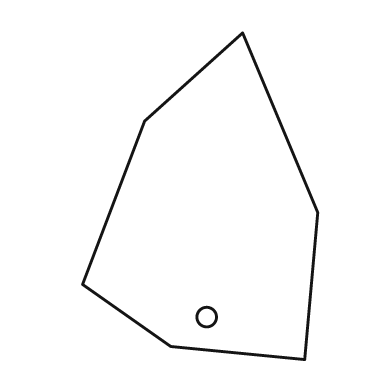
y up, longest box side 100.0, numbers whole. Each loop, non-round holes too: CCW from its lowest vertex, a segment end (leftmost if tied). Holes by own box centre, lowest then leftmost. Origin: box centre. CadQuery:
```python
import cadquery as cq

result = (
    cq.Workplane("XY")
    .moveTo(32.0, -50.0)
    .lineTo(36.0, -5.0)
    .lineTo(13.0, 50.0)
    .lineTo(-17.0, 23.0)
    .lineTo(-36.0, -27.0)
    .lineTo(-9.0, -46.0)
    .close()
    .moveTo(2.0, -37.0)
    .circle(3.0)
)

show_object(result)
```